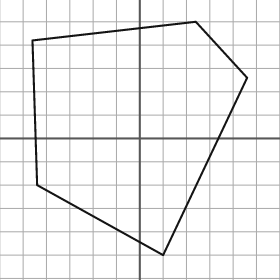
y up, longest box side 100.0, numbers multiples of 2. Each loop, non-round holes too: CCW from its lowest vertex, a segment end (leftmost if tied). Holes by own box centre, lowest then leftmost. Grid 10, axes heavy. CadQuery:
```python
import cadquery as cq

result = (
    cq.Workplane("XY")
    .moveTo(10.0, -50.0)
    .lineTo(46.0, 26.0)
    .lineTo(24.0, 50.0)
    .lineTo(-46.0, 42.0)
    .lineTo(-44.0, -20.0)
    .close()
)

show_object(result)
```